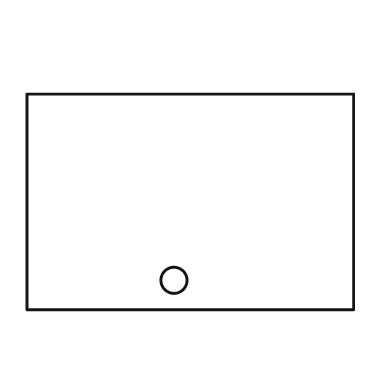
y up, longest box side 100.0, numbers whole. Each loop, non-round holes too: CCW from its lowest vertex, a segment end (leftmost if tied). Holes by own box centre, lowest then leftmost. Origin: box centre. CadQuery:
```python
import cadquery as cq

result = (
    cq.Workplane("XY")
    .moveTo(-50.0, -33.0)
    .lineTo(50.0, -33.0)
    .lineTo(50.0, 33.0)
    .lineTo(-50.0, 33.0)
    .close()
    .moveTo(-5.0, -24.0)
    .circle(4.0)
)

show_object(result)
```